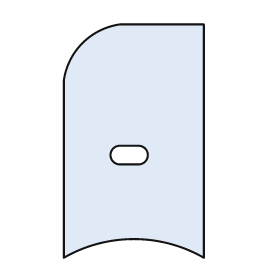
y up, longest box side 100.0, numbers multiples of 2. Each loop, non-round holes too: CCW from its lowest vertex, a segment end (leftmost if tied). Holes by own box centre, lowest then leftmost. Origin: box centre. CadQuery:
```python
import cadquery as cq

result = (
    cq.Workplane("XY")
    .moveTo(-30.0, -50.0)
    .threePointArc((0.0, -42.0), (30.0, -50.0))
    .lineTo(30.0, 50.0)
    .lineTo(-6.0, 50.0)
    .threePointArc((-22.0, 42.0), (-30.0, 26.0))
    .close()
    .moveTo(-6.0, -10.0)
    .lineTo(2.0, -10.0)
    .threePointArc((6.0, -6.0), (2.0, -2.0))
    .lineTo(-6.0, -2.0)
    .threePointArc((-10.0, -6.0), (-6.0, -10.0))
    .close()
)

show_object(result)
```